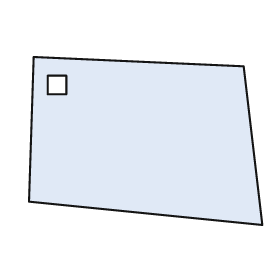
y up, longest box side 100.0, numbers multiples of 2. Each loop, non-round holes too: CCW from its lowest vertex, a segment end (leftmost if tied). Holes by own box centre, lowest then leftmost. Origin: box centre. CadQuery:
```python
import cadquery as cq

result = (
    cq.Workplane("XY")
    .moveTo(50.0, -36.0)
    .lineTo(42.0, 32.0)
    .lineTo(-48.0, 36.0)
    .lineTo(-50.0, -26.0)
    .close()
    .moveTo(-42.0, 20.0)
    .lineTo(-34.0, 20.0)
    .lineTo(-34.0, 28.0)
    .lineTo(-42.0, 28.0)
    .close()
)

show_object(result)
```